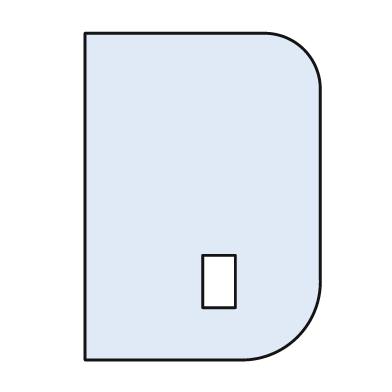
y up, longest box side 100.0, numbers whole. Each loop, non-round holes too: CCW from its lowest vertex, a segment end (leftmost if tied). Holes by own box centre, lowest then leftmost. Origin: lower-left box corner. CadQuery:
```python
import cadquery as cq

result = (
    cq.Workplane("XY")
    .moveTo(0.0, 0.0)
    .lineTo(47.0, 0.0)
    .threePointArc((65.0, 7.0), (72.0, 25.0))
    .lineTo(72.0, 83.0)
    .threePointArc((67.0, 95.0), (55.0, 100.0))
    .lineTo(0.0, 100.0)
    .close()
    .moveTo(36.0, 16.0)
    .lineTo(46.0, 16.0)
    .lineTo(46.0, 32.0)
    .lineTo(36.0, 32.0)
    .close()
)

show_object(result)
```